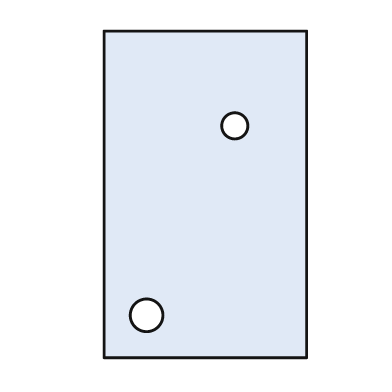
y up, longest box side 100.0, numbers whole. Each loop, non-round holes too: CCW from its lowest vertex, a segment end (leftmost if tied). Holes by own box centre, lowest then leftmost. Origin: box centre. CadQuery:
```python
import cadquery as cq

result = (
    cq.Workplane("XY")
    .moveTo(-31.0, -50.0)
    .lineTo(31.0, -50.0)
    .lineTo(31.0, 50.0)
    .lineTo(-31.0, 50.0)
    .close()
    .moveTo(-18.0, -37.0)
    .circle(5.0)
    .moveTo(9.0, 21.0)
    .circle(4.0)
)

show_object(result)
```